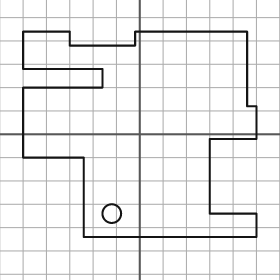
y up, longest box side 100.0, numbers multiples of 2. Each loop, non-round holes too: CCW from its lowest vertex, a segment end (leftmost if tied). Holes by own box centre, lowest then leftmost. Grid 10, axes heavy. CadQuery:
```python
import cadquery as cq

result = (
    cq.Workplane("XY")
    .moveTo(-24.0, -44.0)
    .lineTo(50.0, -44.0)
    .lineTo(50.0, -34.0)
    .lineTo(30.0, -34.0)
    .lineTo(30.0, -2.0)
    .lineTo(50.0, -2.0)
    .lineTo(50.0, 12.0)
    .lineTo(46.0, 12.0)
    .lineTo(46.0, 44.0)
    .lineTo(-2.0, 44.0)
    .lineTo(-2.0, 38.0)
    .lineTo(-30.0, 38.0)
    .lineTo(-30.0, 44.0)
    .lineTo(-50.0, 44.0)
    .lineTo(-50.0, 28.0)
    .lineTo(-16.0, 28.0)
    .lineTo(-16.0, 20.0)
    .lineTo(-50.0, 20.0)
    .lineTo(-50.0, -10.0)
    .lineTo(-24.0, -10.0)
    .close()
    .moveTo(-12.0, -34.0)
    .circle(4.0)
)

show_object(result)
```